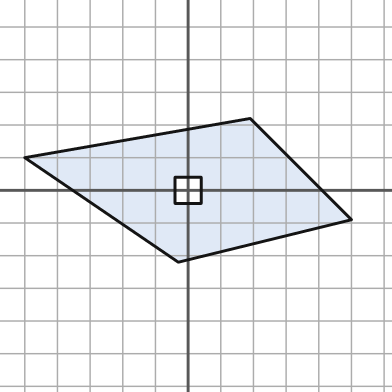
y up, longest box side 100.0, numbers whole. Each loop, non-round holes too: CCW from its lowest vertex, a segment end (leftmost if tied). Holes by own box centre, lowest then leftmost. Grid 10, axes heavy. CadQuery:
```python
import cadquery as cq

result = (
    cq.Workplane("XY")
    .moveTo(-3.0, -22.0)
    .lineTo(50.0, -9.0)
    .lineTo(19.0, 22.0)
    .lineTo(-50.0, 10.0)
    .close()
    .moveTo(-4.0, -4.0)
    .lineTo(4.0, -4.0)
    .lineTo(4.0, 4.0)
    .lineTo(-4.0, 4.0)
    .close()
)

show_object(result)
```